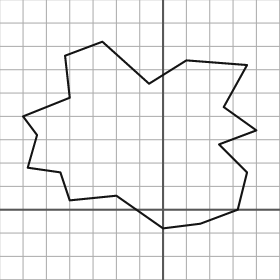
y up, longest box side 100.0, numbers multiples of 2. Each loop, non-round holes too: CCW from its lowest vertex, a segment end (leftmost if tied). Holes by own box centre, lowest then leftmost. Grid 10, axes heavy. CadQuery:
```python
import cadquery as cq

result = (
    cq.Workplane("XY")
    .moveTo(0.0, -8.0)
    .lineTo(16.0, -6.0)
    .lineTo(32.0, 0.0)
    .lineTo(36.0, 16.0)
    .lineTo(24.0, 28.0)
    .lineTo(40.0, 34.0)
    .lineTo(26.0, 44.0)
    .lineTo(36.0, 62.0)
    .lineTo(10.0, 64.0)
    .lineTo(-6.0, 54.0)
    .lineTo(-26.0, 72.0)
    .lineTo(-42.0, 66.0)
    .lineTo(-40.0, 48.0)
    .lineTo(-60.0, 40.0)
    .lineTo(-54.0, 32.0)
    .lineTo(-58.0, 18.0)
    .lineTo(-44.0, 16.0)
    .lineTo(-40.0, 4.0)
    .lineTo(-20.0, 6.0)
    .close()
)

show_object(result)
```